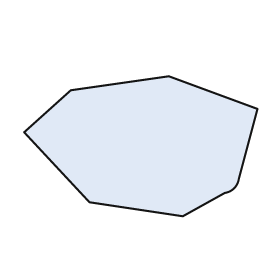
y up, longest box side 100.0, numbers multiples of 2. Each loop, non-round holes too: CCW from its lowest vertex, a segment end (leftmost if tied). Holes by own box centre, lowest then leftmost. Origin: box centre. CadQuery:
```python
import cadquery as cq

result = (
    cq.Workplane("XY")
    .moveTo(18.0, -30.0)
    .lineTo(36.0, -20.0)
    .threePointArc((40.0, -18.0), (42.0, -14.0))
    .lineTo(50.0, 16.0)
    .lineTo(12.0, 30.0)
    .lineTo(-30.0, 24.0)
    .lineTo(-50.0, 6.0)
    .lineTo(-22.0, -24.0)
    .close()
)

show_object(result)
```